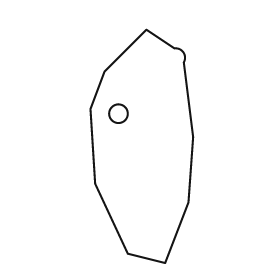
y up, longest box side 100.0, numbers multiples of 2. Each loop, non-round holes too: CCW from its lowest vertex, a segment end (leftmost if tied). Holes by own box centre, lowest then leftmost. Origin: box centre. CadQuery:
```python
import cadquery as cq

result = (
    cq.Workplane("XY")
    .moveTo(10.0, -50.0)
    .lineTo(20.0, -24.0)
    .lineTo(22.0, 4.0)
    .lineTo(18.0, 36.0)
    .threePointArc((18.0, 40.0), (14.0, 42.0))
    .lineTo(2.0, 50.0)
    .lineTo(-16.0, 32.0)
    .lineTo(-22.0, 16.0)
    .lineTo(-20.0, -16.0)
    .lineTo(-6.0, -46.0)
    .close()
    .moveTo(-10.0, 14.0)
    .circle(4.0)
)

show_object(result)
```